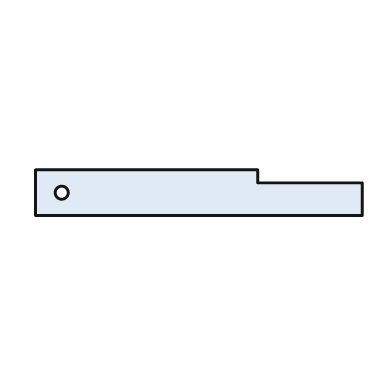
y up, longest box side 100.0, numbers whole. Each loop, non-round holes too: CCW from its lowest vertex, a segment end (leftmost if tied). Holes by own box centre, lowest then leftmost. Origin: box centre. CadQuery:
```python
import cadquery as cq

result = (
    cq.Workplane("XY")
    .moveTo(-50.0, -7.0)
    .lineTo(50.0, -7.0)
    .lineTo(50.0, 3.0)
    .lineTo(18.0, 3.0)
    .lineTo(18.0, 7.0)
    .lineTo(-50.0, 7.0)
    .close()
    .moveTo(-42.0, 0.0)
    .circle(2.0)
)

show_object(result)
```